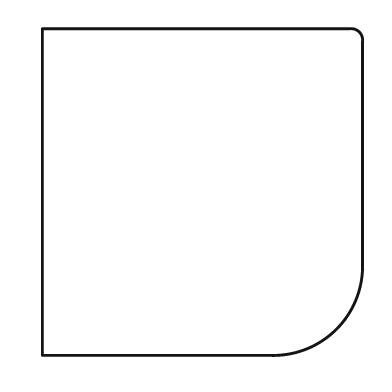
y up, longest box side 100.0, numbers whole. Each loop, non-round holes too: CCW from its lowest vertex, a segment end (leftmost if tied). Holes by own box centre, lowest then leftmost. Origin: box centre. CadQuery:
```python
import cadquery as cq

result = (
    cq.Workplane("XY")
    .moveTo(-49.0, -50.0)
    .lineTo(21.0, -50.0)
    .threePointArc((41.0, -42.0), (49.0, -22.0))
    .lineTo(49.0, 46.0)
    .threePointArc((48.0, 49.0), (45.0, 50.0))
    .lineTo(-49.0, 50.0)
    .close()
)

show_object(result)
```